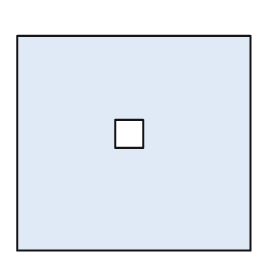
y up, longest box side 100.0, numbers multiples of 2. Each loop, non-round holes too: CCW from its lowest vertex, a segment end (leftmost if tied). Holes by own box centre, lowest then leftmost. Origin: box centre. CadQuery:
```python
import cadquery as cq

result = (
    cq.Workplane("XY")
    .moveTo(-50.0, -46.0)
    .lineTo(50.0, -46.0)
    .lineTo(50.0, 46.0)
    .lineTo(-50.0, 46.0)
    .close()
    .moveTo(-8.0, -2.0)
    .lineTo(4.0, -2.0)
    .lineTo(4.0, 10.0)
    .lineTo(-8.0, 10.0)
    .close()
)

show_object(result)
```